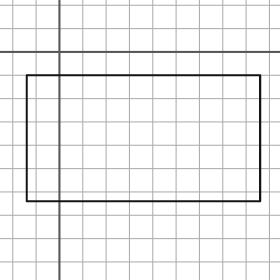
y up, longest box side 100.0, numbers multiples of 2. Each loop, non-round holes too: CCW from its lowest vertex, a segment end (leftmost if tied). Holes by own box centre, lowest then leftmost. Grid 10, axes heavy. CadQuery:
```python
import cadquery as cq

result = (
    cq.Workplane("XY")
    .moveTo(-14.0, -64.0)
    .lineTo(86.0, -64.0)
    .lineTo(86.0, -10.0)
    .lineTo(-14.0, -10.0)
    .close()
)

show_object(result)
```